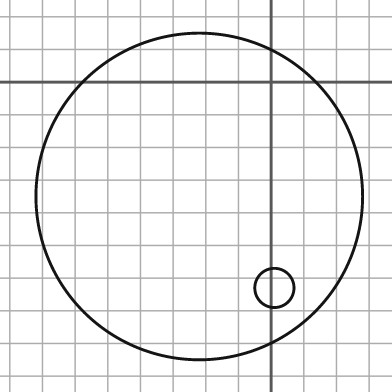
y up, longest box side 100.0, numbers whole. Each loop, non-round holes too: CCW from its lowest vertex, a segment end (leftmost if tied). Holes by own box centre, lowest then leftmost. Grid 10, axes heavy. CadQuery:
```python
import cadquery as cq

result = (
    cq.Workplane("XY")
    .moveTo(-22.0, -35.0)
    .circle(50.0)
    .moveTo(1.0, -63.0)
    .circle(6.0)
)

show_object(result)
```